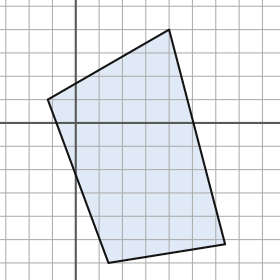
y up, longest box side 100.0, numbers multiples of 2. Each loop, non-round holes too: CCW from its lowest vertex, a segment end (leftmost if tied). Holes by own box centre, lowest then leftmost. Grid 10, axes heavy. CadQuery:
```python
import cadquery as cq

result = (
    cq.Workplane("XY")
    .moveTo(14.0, -60.0)
    .lineTo(64.0, -52.0)
    .lineTo(40.0, 40.0)
    .lineTo(-12.0, 10.0)
    .close()
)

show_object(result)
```